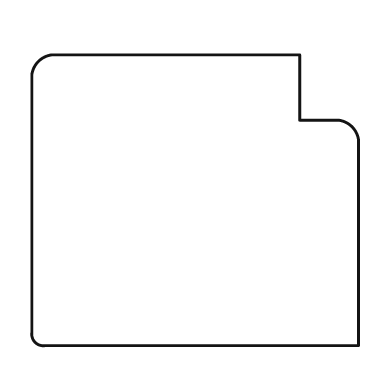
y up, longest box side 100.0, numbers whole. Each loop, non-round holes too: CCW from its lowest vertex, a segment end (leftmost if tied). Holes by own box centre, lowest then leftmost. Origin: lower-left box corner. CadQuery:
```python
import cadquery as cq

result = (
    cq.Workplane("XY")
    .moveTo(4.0, 0.0)
    .lineTo(100.0, 0.0)
    .lineTo(100.0, 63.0)
    .threePointArc((98.0, 67.0), (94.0, 69.0))
    .lineTo(82.0, 69.0)
    .lineTo(82.0, 89.0)
    .lineTo(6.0, 89.0)
    .threePointArc((2.0, 87.0), (0.0, 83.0))
    .lineTo(0.0, 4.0)
    .threePointArc((1.0, 1.0), (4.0, 0.0))
    .close()
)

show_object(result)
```